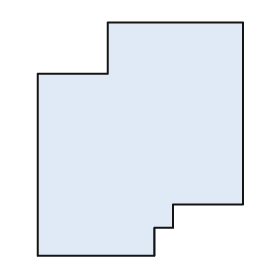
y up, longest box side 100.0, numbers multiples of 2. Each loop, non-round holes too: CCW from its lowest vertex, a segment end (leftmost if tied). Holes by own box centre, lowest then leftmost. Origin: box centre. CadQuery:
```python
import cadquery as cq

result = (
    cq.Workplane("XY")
    .moveTo(-44.0, -50.0)
    .lineTo(6.0, -50.0)
    .lineTo(6.0, -38.0)
    .lineTo(14.0, -38.0)
    .lineTo(14.0, -28.0)
    .lineTo(44.0, -28.0)
    .lineTo(44.0, 50.0)
    .lineTo(-14.0, 50.0)
    .lineTo(-14.0, 28.0)
    .lineTo(-44.0, 28.0)
    .close()
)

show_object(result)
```